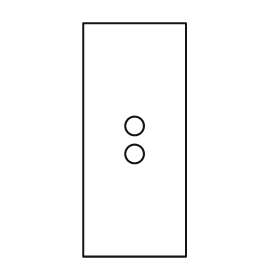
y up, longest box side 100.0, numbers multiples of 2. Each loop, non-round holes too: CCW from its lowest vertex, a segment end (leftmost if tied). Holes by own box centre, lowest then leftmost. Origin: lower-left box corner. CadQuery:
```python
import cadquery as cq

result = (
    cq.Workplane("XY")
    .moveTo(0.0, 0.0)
    .lineTo(44.0, 0.0)
    .lineTo(44.0, 100.0)
    .lineTo(0.0, 100.0)
    .close()
    .moveTo(22.0, 44.0)
    .circle(4.0)
    .moveTo(22.0, 56.0)
    .circle(4.0)
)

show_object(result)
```